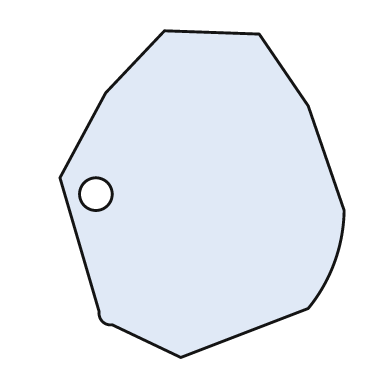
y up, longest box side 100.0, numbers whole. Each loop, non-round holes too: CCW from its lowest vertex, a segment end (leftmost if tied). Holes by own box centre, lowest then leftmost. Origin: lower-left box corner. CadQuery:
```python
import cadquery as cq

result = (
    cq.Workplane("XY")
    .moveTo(37.0, 0.0)
    .lineTo(76.0, 15.0)
    .threePointArc((84.0, 29.0), (87.0, 45.0))
    .lineTo(76.0, 77.0)
    .lineTo(61.0, 99.0)
    .lineTo(32.0, 100.0)
    .lineTo(14.0, 81.0)
    .lineTo(0.0, 55.0)
    .lineTo(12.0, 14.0)
    .threePointArc((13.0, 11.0), (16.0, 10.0))
    .close()
    .moveTo(11.0, 50.0)
    .circle(5.0)
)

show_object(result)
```